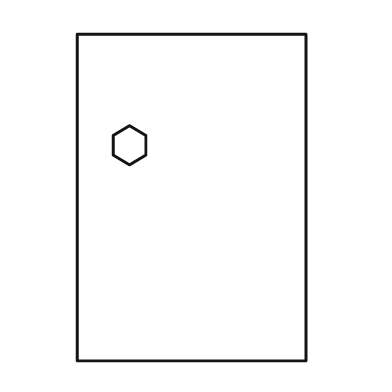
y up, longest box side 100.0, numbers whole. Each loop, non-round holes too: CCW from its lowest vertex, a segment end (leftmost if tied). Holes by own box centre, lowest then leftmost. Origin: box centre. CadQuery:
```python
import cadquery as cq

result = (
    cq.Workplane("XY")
    .moveTo(-35.0, -50.0)
    .lineTo(35.0, -50.0)
    .lineTo(35.0, 50.0)
    .lineTo(-35.0, 50.0)
    .close()
    .moveTo(-19.0, 10.0)
    .lineTo(-14.0, 13.0)
    .lineTo(-14.0, 19.0)
    .lineTo(-19.0, 22.0)
    .lineTo(-24.0, 19.0)
    .lineTo(-24.0, 13.0)
    .close()
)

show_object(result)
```